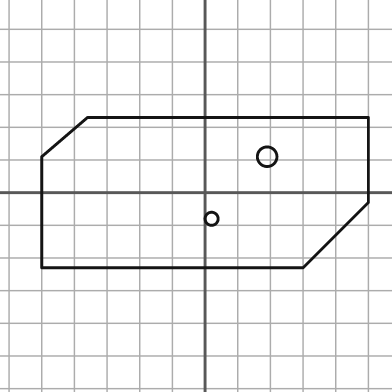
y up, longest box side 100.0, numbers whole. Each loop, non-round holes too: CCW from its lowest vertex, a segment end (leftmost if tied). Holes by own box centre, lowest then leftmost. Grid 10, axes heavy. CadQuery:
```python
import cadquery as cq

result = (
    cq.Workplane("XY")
    .moveTo(-50.0, -23.0)
    .lineTo(30.0, -23.0)
    .lineTo(50.0, -3.0)
    .lineTo(50.0, 23.0)
    .lineTo(-36.0, 23.0)
    .lineTo(-50.0, 11.0)
    .close()
    .moveTo(2.0, -8.0)
    .circle(2.0)
    .moveTo(19.0, 11.0)
    .circle(3.0)
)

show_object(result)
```